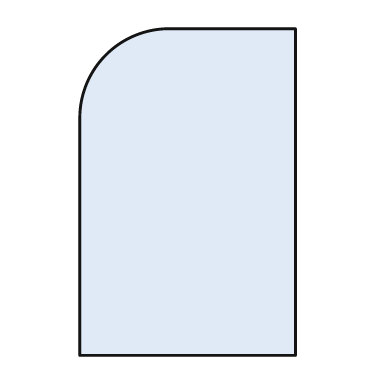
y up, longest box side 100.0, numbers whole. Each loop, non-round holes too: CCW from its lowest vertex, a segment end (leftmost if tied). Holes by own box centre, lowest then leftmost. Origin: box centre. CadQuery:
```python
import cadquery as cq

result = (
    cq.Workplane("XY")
    .moveTo(-33.0, -50.0)
    .lineTo(33.0, -50.0)
    .lineTo(33.0, 50.0)
    .lineTo(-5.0, 50.0)
    .threePointArc((-25.0, 42.0), (-33.0, 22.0))
    .close()
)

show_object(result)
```